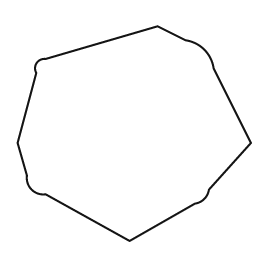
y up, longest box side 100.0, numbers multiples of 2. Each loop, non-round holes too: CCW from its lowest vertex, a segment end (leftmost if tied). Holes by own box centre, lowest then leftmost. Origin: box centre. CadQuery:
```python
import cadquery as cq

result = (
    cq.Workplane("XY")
    .moveTo(-2.0, -46.0)
    .lineTo(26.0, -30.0)
    .threePointArc((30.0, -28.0), (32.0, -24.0))
    .lineTo(50.0, -4.0)
    .lineTo(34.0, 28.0)
    .threePointArc((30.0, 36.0), (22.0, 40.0))
    .lineTo(10.0, 46.0)
    .lineTo(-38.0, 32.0)
    .threePointArc((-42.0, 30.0), (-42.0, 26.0))
    .lineTo(-50.0, -4.0)
    .lineTo(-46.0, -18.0)
    .threePointArc((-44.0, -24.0), (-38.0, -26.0))
    .close()
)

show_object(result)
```